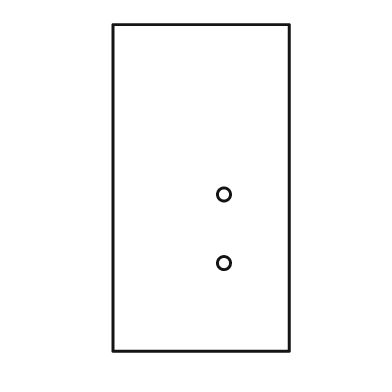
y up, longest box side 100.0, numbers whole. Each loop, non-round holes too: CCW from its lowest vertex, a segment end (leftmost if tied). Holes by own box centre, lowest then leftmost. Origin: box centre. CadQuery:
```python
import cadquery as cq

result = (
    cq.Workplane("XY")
    .moveTo(-27.0, -50.0)
    .lineTo(27.0, -50.0)
    .lineTo(27.0, 50.0)
    .lineTo(-27.0, 50.0)
    .close()
    .moveTo(7.0, -23.0)
    .circle(2.0)
    .moveTo(7.0, -2.0)
    .circle(2.0)
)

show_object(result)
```